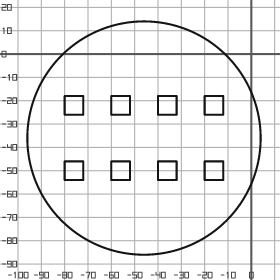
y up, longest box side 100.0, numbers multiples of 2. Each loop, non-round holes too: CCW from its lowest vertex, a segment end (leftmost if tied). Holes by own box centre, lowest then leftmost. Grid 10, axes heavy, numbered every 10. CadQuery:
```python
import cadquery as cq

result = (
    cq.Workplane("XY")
    .moveTo(-46.0, -36.0)
    .circle(50.0)
    .moveTo(-80.0, -54.0)
    .lineTo(-72.0, -54.0)
    .lineTo(-72.0, -46.0)
    .lineTo(-80.0, -46.0)
    .close()
    .moveTo(-60.0, -54.0)
    .lineTo(-52.0, -54.0)
    .lineTo(-52.0, -46.0)
    .lineTo(-60.0, -46.0)
    .close()
    .moveTo(-40.0, -54.0)
    .lineTo(-32.0, -54.0)
    .lineTo(-32.0, -46.0)
    .lineTo(-40.0, -46.0)
    .close()
    .moveTo(-20.0, -54.0)
    .lineTo(-12.0, -54.0)
    .lineTo(-12.0, -46.0)
    .lineTo(-20.0, -46.0)
    .close()
    .moveTo(-80.0, -26.0)
    .lineTo(-72.0, -26.0)
    .lineTo(-72.0, -18.0)
    .lineTo(-80.0, -18.0)
    .close()
    .moveTo(-60.0, -26.0)
    .lineTo(-52.0, -26.0)
    .lineTo(-52.0, -18.0)
    .lineTo(-60.0, -18.0)
    .close()
    .moveTo(-40.0, -26.0)
    .lineTo(-32.0, -26.0)
    .lineTo(-32.0, -18.0)
    .lineTo(-40.0, -18.0)
    .close()
    .moveTo(-20.0, -26.0)
    .lineTo(-12.0, -26.0)
    .lineTo(-12.0, -18.0)
    .lineTo(-20.0, -18.0)
    .close()
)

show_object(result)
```